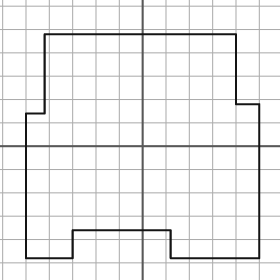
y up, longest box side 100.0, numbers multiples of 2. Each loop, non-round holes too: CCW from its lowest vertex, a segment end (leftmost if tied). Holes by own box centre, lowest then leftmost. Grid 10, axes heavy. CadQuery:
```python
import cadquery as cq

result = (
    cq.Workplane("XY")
    .moveTo(-50.0, -48.0)
    .lineTo(-30.0, -48.0)
    .lineTo(-30.0, -36.0)
    .lineTo(12.0, -36.0)
    .lineTo(12.0, -48.0)
    .lineTo(50.0, -48.0)
    .lineTo(50.0, 18.0)
    .lineTo(40.0, 18.0)
    .lineTo(40.0, 48.0)
    .lineTo(-42.0, 48.0)
    .lineTo(-42.0, 14.0)
    .lineTo(-50.0, 14.0)
    .close()
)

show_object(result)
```